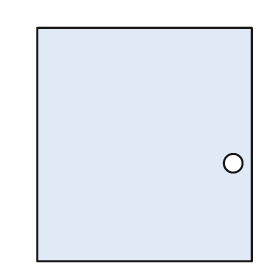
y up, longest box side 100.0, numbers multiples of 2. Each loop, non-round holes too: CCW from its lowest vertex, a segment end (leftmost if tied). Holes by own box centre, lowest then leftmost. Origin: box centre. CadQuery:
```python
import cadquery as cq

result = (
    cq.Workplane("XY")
    .moveTo(-46.0, -50.0)
    .lineTo(46.0, -50.0)
    .lineTo(46.0, 50.0)
    .lineTo(-46.0, 50.0)
    .close()
    .moveTo(38.0, -8.0)
    .circle(4.0)
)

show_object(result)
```